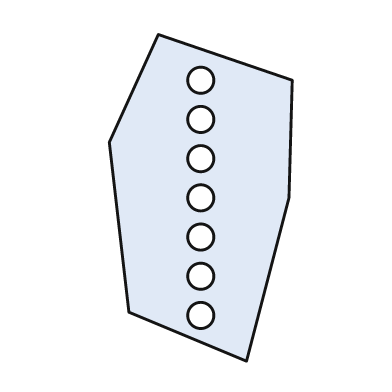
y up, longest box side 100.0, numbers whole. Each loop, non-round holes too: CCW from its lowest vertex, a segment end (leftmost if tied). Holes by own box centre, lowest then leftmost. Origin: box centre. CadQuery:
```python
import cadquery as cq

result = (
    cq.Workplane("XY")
    .moveTo(14.0, -50.0)
    .lineTo(27.0, 0.0)
    .lineTo(28.0, 36.0)
    .lineTo(-13.0, 50.0)
    .lineTo(-28.0, 17.0)
    .lineTo(-22.0, -35.0)
    .close()
    .moveTo(0.0, -36.0)
    .circle(4.0)
    .moveTo(0.0, -24.0)
    .circle(4.0)
    .moveTo(0.0, -12.0)
    .circle(4.0)
    .moveTo(0.0, 0.0)
    .circle(4.0)
    .moveTo(0.0, 12.0)
    .circle(4.0)
    .moveTo(0.0, 24.0)
    .circle(4.0)
    .moveTo(0.0, 36.0)
    .circle(4.0)
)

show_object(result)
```